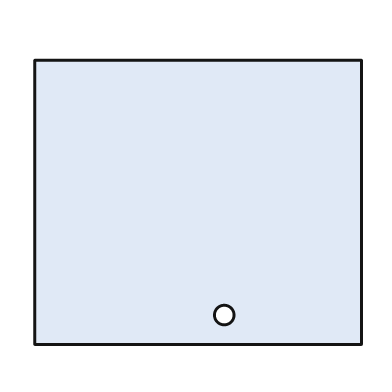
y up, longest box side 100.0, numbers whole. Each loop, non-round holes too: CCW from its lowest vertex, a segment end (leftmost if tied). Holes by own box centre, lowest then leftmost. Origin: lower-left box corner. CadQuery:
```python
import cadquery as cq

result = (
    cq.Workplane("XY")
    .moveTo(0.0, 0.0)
    .lineTo(100.0, 0.0)
    .lineTo(100.0, 87.0)
    .lineTo(0.0, 87.0)
    .close()
    .moveTo(58.0, 9.0)
    .circle(3.0)
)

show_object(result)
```